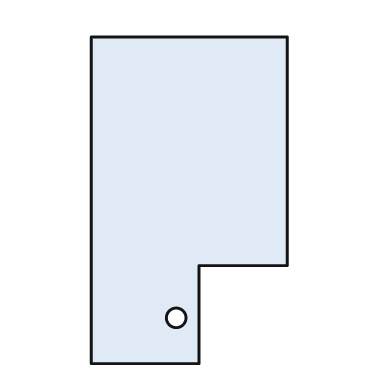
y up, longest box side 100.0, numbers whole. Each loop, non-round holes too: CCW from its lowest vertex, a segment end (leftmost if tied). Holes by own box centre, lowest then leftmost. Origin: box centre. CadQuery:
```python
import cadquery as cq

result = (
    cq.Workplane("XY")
    .moveTo(-30.0, -50.0)
    .lineTo(3.0, -50.0)
    .lineTo(3.0, -20.0)
    .lineTo(30.0, -20.0)
    .lineTo(30.0, 50.0)
    .lineTo(-30.0, 50.0)
    .close()
    .moveTo(-4.0, -36.0)
    .circle(3.0)
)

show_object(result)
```